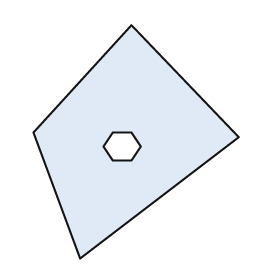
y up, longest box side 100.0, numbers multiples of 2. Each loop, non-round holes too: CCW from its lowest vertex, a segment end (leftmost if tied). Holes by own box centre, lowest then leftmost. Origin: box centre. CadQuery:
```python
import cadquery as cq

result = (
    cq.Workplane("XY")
    .moveTo(-24.0, -50.0)
    .lineTo(44.0, 2.0)
    .lineTo(-2.0, 50.0)
    .lineTo(-44.0, 4.0)
    .close()
    .moveTo(-10.0, -8.0)
    .lineTo(-2.0, -8.0)
    .lineTo(2.0, -2.0)
    .lineTo(-2.0, 4.0)
    .lineTo(-10.0, 4.0)
    .lineTo(-14.0, -2.0)
    .close()
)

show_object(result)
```